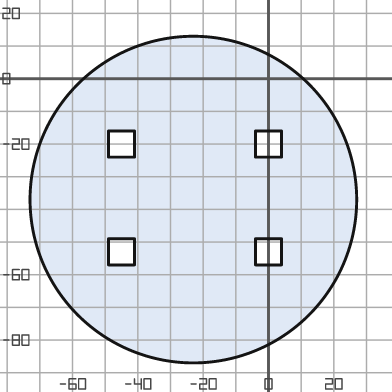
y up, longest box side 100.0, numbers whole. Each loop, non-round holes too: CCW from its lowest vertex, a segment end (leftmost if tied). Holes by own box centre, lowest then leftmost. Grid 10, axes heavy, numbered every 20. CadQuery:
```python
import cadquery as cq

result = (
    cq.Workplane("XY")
    .moveTo(-23.0, -37.0)
    .circle(50.0)
    .moveTo(-49.0, -57.0)
    .lineTo(-41.0, -57.0)
    .lineTo(-41.0, -49.0)
    .lineTo(-49.0, -49.0)
    .close()
    .moveTo(-4.0, -57.0)
    .lineTo(4.0, -57.0)
    .lineTo(4.0, -49.0)
    .lineTo(-4.0, -49.0)
    .close()
    .moveTo(-49.0, -24.0)
    .lineTo(-41.0, -24.0)
    .lineTo(-41.0, -16.0)
    .lineTo(-49.0, -16.0)
    .close()
    .moveTo(-4.0, -24.0)
    .lineTo(4.0, -24.0)
    .lineTo(4.0, -16.0)
    .lineTo(-4.0, -16.0)
    .close()
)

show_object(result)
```